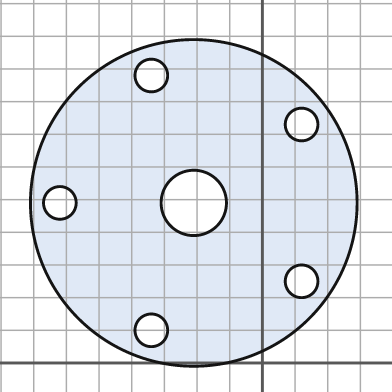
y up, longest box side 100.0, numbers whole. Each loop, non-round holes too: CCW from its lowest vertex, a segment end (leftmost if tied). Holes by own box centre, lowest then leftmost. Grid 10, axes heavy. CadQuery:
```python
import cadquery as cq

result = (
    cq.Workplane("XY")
    .moveTo(-21.0, 49.0)
    .circle(50.0)
    .moveTo(-34.0, 10.0)
    .circle(5.0)
    .moveTo(12.0, 25.0)
    .circle(5.0)
    .moveTo(-62.0, 49.0)
    .circle(5.0)
    .moveTo(-21.0, 49.0)
    .circle(10.0)
    .moveTo(12.0, 73.0)
    .circle(5.0)
    .moveTo(-34.0, 88.0)
    .circle(5.0)
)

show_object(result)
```